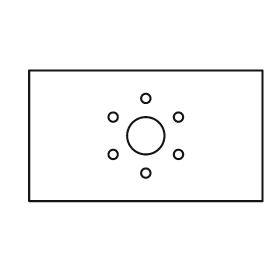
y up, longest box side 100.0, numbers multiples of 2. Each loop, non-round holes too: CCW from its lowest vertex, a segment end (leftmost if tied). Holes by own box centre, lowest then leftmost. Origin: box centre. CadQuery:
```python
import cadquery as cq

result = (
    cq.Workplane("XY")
    .moveTo(-50.0, -28.0)
    .lineTo(50.0, -28.0)
    .lineTo(50.0, 28.0)
    .lineTo(-50.0, 28.0)
    .close()
    .moveTo(0.0, -16.0)
    .circle(2.0)
    .moveTo(-14.0, -8.0)
    .circle(2.0)
    .moveTo(14.0, -8.0)
    .circle(2.0)
    .moveTo(0.0, 0.0)
    .circle(8.0)
    .moveTo(-14.0, 8.0)
    .circle(2.0)
    .moveTo(14.0, 8.0)
    .circle(2.0)
    .moveTo(0.0, 16.0)
    .circle(2.0)
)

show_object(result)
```